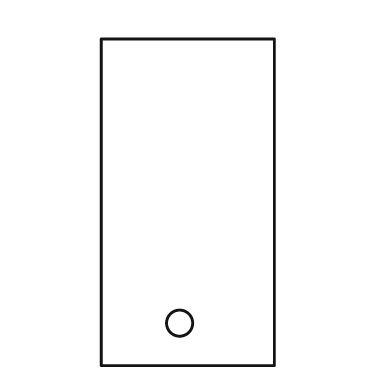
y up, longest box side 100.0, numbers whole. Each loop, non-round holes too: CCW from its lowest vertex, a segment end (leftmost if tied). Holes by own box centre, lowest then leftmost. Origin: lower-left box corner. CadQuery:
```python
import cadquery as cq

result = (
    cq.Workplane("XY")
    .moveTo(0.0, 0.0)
    .lineTo(53.0, 0.0)
    .lineTo(53.0, 100.0)
    .lineTo(0.0, 100.0)
    .close()
    .moveTo(24.0, 13.0)
    .circle(4.0)
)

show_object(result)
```